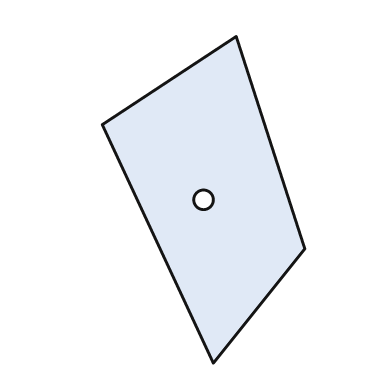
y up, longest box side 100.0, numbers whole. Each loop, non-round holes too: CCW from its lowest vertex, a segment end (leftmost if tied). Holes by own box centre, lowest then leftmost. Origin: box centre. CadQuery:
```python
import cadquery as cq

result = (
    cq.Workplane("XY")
    .moveTo(3.0, -50.0)
    .lineTo(31.0, -15.0)
    .lineTo(10.0, 50.0)
    .lineTo(-31.0, 23.0)
    .close()
    .moveTo(0.0, 0.0)
    .circle(3.0)
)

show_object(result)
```